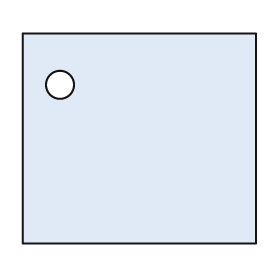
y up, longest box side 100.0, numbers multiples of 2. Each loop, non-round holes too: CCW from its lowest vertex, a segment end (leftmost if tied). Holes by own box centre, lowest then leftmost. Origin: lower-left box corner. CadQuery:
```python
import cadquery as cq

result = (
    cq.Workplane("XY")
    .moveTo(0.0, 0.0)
    .lineTo(100.0, 0.0)
    .lineTo(100.0, 90.0)
    .lineTo(0.0, 90.0)
    .close()
    .moveTo(16.0, 68.0)
    .circle(6.0)
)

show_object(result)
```